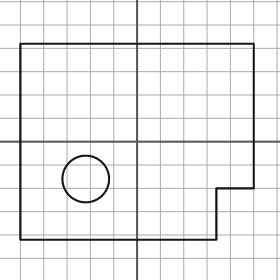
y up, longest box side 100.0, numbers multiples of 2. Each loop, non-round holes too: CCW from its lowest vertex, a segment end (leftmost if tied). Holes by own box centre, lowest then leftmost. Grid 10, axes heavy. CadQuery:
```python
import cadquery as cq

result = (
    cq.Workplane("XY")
    .moveTo(-50.0, -42.0)
    .lineTo(34.0, -42.0)
    .lineTo(34.0, -20.0)
    .lineTo(50.0, -20.0)
    .lineTo(50.0, 42.0)
    .lineTo(-50.0, 42.0)
    .close()
    .moveTo(-22.0, -16.0)
    .circle(10.0)
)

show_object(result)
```